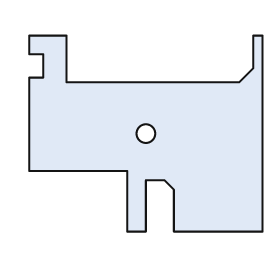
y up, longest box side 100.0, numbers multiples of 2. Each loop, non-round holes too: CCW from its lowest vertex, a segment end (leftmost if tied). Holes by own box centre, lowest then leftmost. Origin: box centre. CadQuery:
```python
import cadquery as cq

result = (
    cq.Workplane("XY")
    .moveTo(-8.0, -42.0)
    .lineTo(0.0, -42.0)
    .lineTo(0.0, -20.0)
    .lineTo(8.0, -20.0)
    .lineTo(12.0, -24.0)
    .lineTo(12.0, -42.0)
    .lineTo(50.0, -42.0)
    .lineTo(50.0, 42.0)
    .lineTo(46.0, 42.0)
    .lineTo(46.0, 28.0)
    .lineTo(40.0, 22.0)
    .lineTo(-34.0, 22.0)
    .lineTo(-34.0, 42.0)
    .lineTo(-50.0, 42.0)
    .lineTo(-50.0, 34.0)
    .lineTo(-44.0, 34.0)
    .lineTo(-44.0, 24.0)
    .lineTo(-50.0, 24.0)
    .lineTo(-50.0, -16.0)
    .lineTo(-8.0, -16.0)
    .close()
    .moveTo(0.0, 0.0)
    .circle(4.0)
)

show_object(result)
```